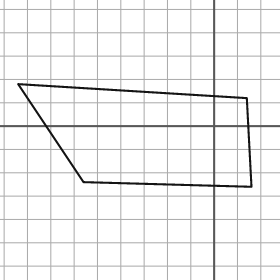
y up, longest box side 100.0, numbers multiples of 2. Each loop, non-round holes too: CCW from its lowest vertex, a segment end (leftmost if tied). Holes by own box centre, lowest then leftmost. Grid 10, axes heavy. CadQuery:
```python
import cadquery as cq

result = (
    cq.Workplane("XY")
    .moveTo(16.0, -26.0)
    .lineTo(14.0, 12.0)
    .lineTo(-84.0, 18.0)
    .lineTo(-56.0, -24.0)
    .close()
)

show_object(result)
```